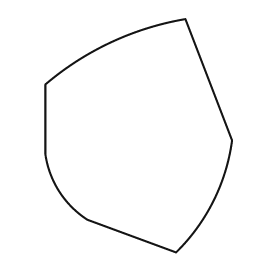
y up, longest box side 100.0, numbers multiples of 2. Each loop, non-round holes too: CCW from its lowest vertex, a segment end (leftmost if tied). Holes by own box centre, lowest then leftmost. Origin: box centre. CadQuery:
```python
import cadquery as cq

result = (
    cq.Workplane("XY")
    .moveTo(16.0, -50.0)
    .threePointArc((32.0, -28.0), (40.0, -2.0))
    .lineTo(20.0, 50.0)
    .threePointArc((-12.0, 40.0), (-40.0, 22.0))
    .lineTo(-40.0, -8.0)
    .threePointArc((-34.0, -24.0), (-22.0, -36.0))
    .close()
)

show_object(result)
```